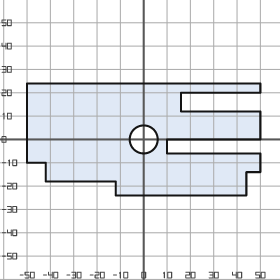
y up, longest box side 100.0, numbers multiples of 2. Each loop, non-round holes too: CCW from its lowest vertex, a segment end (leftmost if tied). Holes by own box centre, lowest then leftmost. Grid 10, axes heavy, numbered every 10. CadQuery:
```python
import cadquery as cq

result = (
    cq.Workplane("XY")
    .moveTo(-12.0, -24.0)
    .lineTo(44.0, -24.0)
    .lineTo(44.0, -14.0)
    .lineTo(50.0, -14.0)
    .lineTo(50.0, -6.0)
    .lineTo(10.0, -6.0)
    .lineTo(10.0, 0.0)
    .lineTo(50.0, 0.0)
    .lineTo(50.0, 12.0)
    .lineTo(16.0, 12.0)
    .lineTo(16.0, 20.0)
    .lineTo(50.0, 20.0)
    .lineTo(50.0, 24.0)
    .lineTo(-50.0, 24.0)
    .lineTo(-50.0, -10.0)
    .lineTo(-42.0, -10.0)
    .lineTo(-42.0, -18.0)
    .lineTo(-12.0, -18.0)
    .close()
    .moveTo(0.0, 0.0)
    .circle(6.0)
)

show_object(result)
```